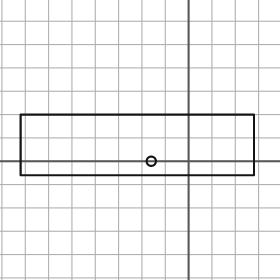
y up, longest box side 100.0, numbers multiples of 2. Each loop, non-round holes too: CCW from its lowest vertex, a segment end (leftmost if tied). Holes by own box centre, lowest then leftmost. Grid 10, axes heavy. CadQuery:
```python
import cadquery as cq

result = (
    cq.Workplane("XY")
    .moveTo(-72.0, -6.0)
    .lineTo(28.0, -6.0)
    .lineTo(28.0, 20.0)
    .lineTo(-72.0, 20.0)
    .close()
    .moveTo(-16.0, 0.0)
    .circle(2.0)
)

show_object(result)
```